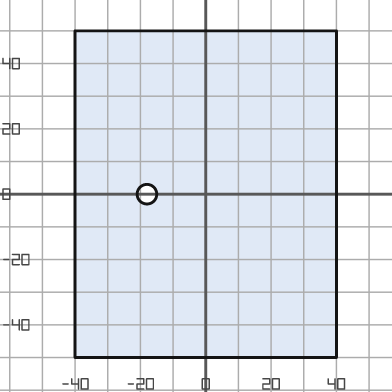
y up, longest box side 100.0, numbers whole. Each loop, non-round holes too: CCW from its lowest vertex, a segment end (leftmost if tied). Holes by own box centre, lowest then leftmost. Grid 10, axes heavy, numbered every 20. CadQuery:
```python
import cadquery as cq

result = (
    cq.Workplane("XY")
    .moveTo(-40.0, -50.0)
    .lineTo(40.0, -50.0)
    .lineTo(40.0, 50.0)
    .lineTo(-40.0, 50.0)
    .close()
    .moveTo(-18.0, 0.0)
    .circle(3.0)
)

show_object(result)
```